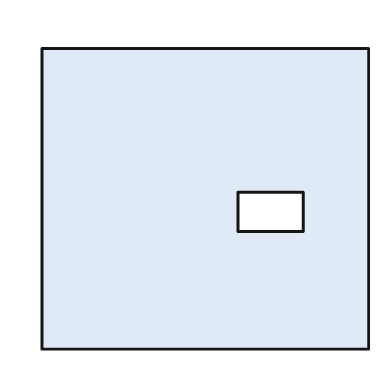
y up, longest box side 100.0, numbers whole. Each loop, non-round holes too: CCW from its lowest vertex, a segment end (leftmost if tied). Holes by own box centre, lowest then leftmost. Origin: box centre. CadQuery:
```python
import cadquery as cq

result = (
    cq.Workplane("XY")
    .moveTo(-50.0, -46.0)
    .lineTo(50.0, -46.0)
    .lineTo(50.0, 46.0)
    .lineTo(-50.0, 46.0)
    .close()
    .moveTo(10.0, -10.0)
    .lineTo(30.0, -10.0)
    .lineTo(30.0, 2.0)
    .lineTo(10.0, 2.0)
    .close()
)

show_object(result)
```